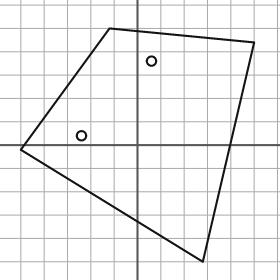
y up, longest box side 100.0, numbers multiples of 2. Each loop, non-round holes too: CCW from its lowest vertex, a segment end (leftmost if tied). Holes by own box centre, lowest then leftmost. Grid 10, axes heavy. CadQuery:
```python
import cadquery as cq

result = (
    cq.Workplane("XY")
    .moveTo(28.0, -50.0)
    .lineTo(50.0, 44.0)
    .lineTo(-12.0, 50.0)
    .lineTo(-50.0, -2.0)
    .close()
    .moveTo(-24.0, 4.0)
    .circle(2.0)
    .moveTo(6.0, 36.0)
    .circle(2.0)
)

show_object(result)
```